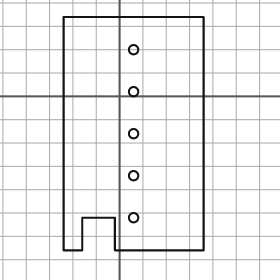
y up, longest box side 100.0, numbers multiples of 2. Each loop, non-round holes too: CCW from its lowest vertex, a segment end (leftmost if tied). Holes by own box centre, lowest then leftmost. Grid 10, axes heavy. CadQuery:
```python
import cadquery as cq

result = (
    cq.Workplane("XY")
    .moveTo(-24.0, -66.0)
    .lineTo(-16.0, -66.0)
    .lineTo(-16.0, -52.0)
    .lineTo(-2.0, -52.0)
    .lineTo(-2.0, -66.0)
    .lineTo(36.0, -66.0)
    .lineTo(36.0, 34.0)
    .lineTo(-24.0, 34.0)
    .close()
    .moveTo(6.0, -52.0)
    .circle(2.0)
    .moveTo(6.0, -34.0)
    .circle(2.0)
    .moveTo(6.0, -16.0)
    .circle(2.0)
    .moveTo(6.0, 2.0)
    .circle(2.0)
    .moveTo(6.0, 20.0)
    .circle(2.0)
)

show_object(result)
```